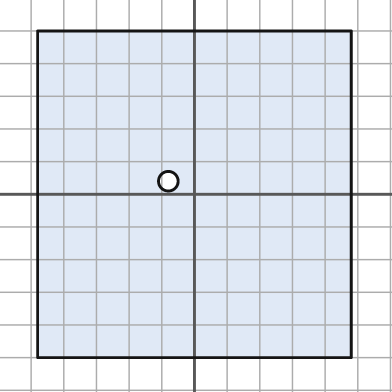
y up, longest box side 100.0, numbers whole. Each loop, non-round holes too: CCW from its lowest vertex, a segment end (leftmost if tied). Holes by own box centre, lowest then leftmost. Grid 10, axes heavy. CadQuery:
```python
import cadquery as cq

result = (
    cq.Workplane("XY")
    .moveTo(-48.0, -50.0)
    .lineTo(48.0, -50.0)
    .lineTo(48.0, 50.0)
    .lineTo(-48.0, 50.0)
    .close()
    .moveTo(-8.0, 4.0)
    .circle(3.0)
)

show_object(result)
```